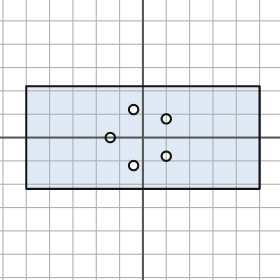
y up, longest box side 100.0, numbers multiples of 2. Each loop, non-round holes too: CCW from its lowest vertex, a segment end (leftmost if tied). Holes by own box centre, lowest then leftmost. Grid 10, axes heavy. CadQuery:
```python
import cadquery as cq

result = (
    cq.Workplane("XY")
    .moveTo(-50.0, -22.0)
    .lineTo(50.0, -22.0)
    .lineTo(50.0, 22.0)
    .lineTo(-50.0, 22.0)
    .close()
    .moveTo(-4.0, -12.0)
    .circle(2.0)
    .moveTo(10.0, -8.0)
    .circle(2.0)
    .moveTo(-14.0, 0.0)
    .circle(2.0)
    .moveTo(10.0, 8.0)
    .circle(2.0)
    .moveTo(-4.0, 12.0)
    .circle(2.0)
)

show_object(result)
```